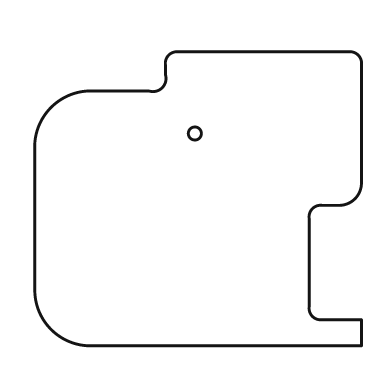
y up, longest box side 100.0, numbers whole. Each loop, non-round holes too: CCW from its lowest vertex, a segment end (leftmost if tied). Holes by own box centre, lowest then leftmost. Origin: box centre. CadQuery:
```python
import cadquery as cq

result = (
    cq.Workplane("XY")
    .moveTo(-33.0, -45.0)
    .lineTo(50.0, -45.0)
    .lineTo(50.0, -37.0)
    .lineTo(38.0, -37.0)
    .threePointArc((35.0, -36.0), (34.0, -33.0))
    .lineTo(34.0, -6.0)
    .threePointArc((35.0, -3.0), (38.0, -2.0))
    .lineTo(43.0, -2.0)
    .threePointArc((48.0, 0.0), (50.0, 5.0))
    .lineTo(50.0, 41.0)
    .threePointArc((49.0, 44.0), (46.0, 45.0))
    .lineTo(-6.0, 45.0)
    .threePointArc((-9.0, 44.0), (-10.0, 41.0))
    .lineTo(-10.0, 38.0)
    .threePointArc((-11.0, 34.0), (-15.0, 33.0))
    .lineTo(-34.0, 33.0)
    .threePointArc((-45.0, 28.0), (-50.0, 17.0))
    .lineTo(-50.0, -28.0)
    .threePointArc((-45.0, -40.0), (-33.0, -45.0))
    .close()
    .moveTo(-1.0, 20.0)
    .circle(2.0)
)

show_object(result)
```